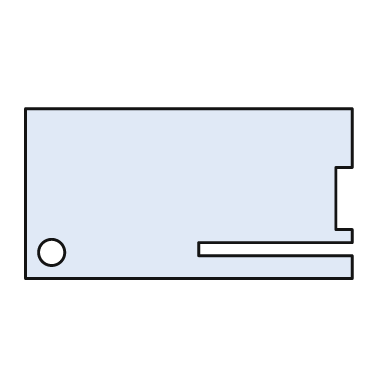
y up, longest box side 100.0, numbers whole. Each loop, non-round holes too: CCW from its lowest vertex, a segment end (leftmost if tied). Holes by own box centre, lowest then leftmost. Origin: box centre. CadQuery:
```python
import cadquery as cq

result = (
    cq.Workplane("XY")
    .moveTo(-50.0, -26.0)
    .lineTo(50.0, -26.0)
    .lineTo(50.0, -19.0)
    .lineTo(3.0, -19.0)
    .lineTo(3.0, -15.0)
    .lineTo(50.0, -15.0)
    .lineTo(50.0, -11.0)
    .lineTo(45.0, -11.0)
    .lineTo(45.0, 8.0)
    .lineTo(50.0, 8.0)
    .lineTo(50.0, 26.0)
    .lineTo(-50.0, 26.0)
    .close()
    .moveTo(-42.0, -18.0)
    .circle(4.0)
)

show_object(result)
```